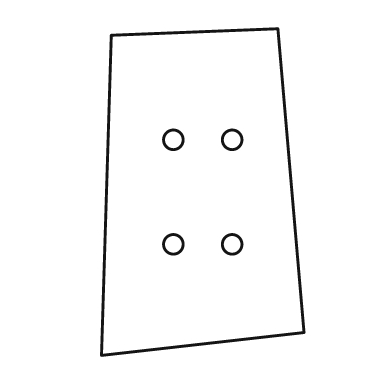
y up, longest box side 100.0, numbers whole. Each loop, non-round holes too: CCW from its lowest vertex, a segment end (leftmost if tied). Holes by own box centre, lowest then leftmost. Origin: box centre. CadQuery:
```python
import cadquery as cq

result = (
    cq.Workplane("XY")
    .moveTo(-31.0, -50.0)
    .lineTo(31.0, -43.0)
    .lineTo(23.0, 50.0)
    .lineTo(-28.0, 48.0)
    .close()
    .moveTo(-9.0, -16.0)
    .circle(3.0)
    .moveTo(9.0, -16.0)
    .circle(3.0)
    .moveTo(-9.0, 16.0)
    .circle(3.0)
    .moveTo(9.0, 16.0)
    .circle(3.0)
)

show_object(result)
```